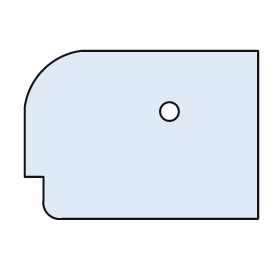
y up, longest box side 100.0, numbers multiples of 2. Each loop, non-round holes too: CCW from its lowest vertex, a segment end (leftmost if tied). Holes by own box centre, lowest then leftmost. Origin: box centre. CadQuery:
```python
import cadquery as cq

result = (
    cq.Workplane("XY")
    .moveTo(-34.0, -36.0)
    .lineTo(50.0, -36.0)
    .lineTo(50.0, 36.0)
    .lineTo(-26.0, 36.0)
    .threePointArc((-42.0, 28.0), (-50.0, 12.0))
    .lineTo(-50.0, -18.0)
    .lineTo(-42.0, -18.0)
    .lineTo(-42.0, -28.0)
    .threePointArc((-40.0, -34.0), (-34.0, -36.0))
    .close()
    .moveTo(12.0, 10.0)
    .circle(4.0)
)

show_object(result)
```